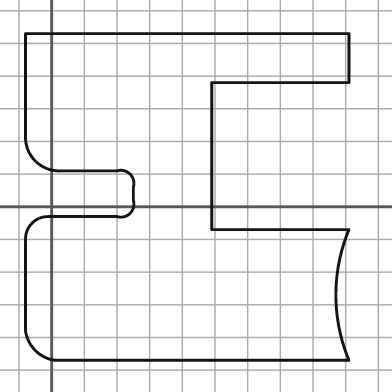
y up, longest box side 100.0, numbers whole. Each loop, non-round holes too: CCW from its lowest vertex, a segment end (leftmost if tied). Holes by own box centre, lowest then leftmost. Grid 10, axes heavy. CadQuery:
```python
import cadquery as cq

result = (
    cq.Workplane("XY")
    .moveTo(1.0, -47.0)
    .lineTo(91.0, -47.0)
    .threePointArc((87.0, -27.0), (91.0, -7.0))
    .lineTo(49.0, -7.0)
    .lineTo(49.0, 38.0)
    .lineTo(91.0, 38.0)
    .lineTo(91.0, 53.0)
    .lineTo(-8.0, 53.0)
    .lineTo(-8.0, 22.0)
    .threePointArc((-5.0, 14.0), (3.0, 11.0))
    .lineTo(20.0, 11.0)
    .threePointArc((24.0, 10.0), (25.0, 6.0))
    .lineTo(25.0, 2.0)
    .threePointArc((24.0, -2.0), (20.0, -3.0))
    .lineTo(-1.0, -3.0)
    .threePointArc((-6.0, -5.0), (-8.0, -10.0))
    .lineTo(-8.0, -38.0)
    .threePointArc((-5.0, -44.0), (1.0, -47.0))
    .close()
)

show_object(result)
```